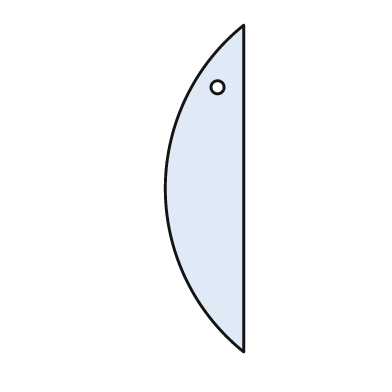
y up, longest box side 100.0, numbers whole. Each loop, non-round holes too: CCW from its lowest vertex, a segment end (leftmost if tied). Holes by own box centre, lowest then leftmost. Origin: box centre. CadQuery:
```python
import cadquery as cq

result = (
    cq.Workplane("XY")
    .moveTo(12.0, -50.0)
    .lineTo(12.0, 50.0)
    .threePointArc((-12.0, 0.0), (12.0, -50.0))
    .close()
    .moveTo(4.0, 31.0)
    .circle(2.0)
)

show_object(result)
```